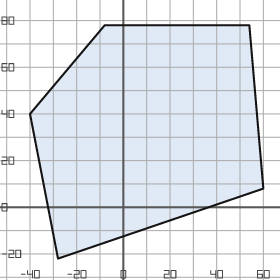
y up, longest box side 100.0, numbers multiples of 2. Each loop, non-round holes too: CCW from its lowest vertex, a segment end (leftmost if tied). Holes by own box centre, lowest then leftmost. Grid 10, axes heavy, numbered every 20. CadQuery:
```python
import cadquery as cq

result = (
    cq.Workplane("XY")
    .moveTo(-28.0, -22.0)
    .lineTo(60.0, 8.0)
    .lineTo(54.0, 78.0)
    .lineTo(-8.0, 78.0)
    .lineTo(-40.0, 40.0)
    .close()
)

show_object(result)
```